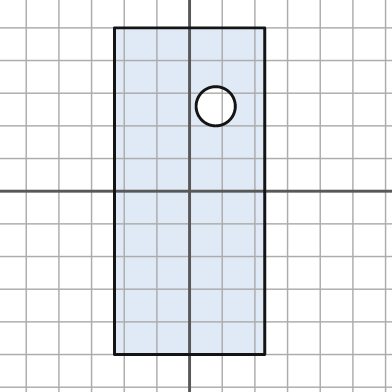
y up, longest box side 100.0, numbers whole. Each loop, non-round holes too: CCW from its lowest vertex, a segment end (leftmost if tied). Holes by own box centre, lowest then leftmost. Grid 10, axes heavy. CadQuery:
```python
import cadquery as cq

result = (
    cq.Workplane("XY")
    .moveTo(-23.0, -50.0)
    .lineTo(23.0, -50.0)
    .lineTo(23.0, 50.0)
    .lineTo(-23.0, 50.0)
    .close()
    .moveTo(8.0, 26.0)
    .circle(6.0)
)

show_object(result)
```